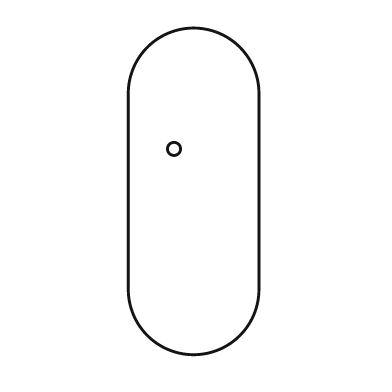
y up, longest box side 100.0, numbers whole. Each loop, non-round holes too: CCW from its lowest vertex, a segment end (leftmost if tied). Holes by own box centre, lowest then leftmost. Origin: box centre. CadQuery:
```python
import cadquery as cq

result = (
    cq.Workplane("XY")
    .moveTo(-20.0, -30.0)
    .threePointArc((0.0, -50.0), (20.0, -30.0))
    .lineTo(20.0, 30.0)
    .threePointArc((0.0, 50.0), (-20.0, 30.0))
    .close()
    .moveTo(-6.0, 13.0)
    .circle(2.0)
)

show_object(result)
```